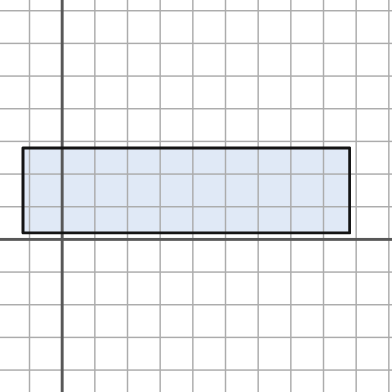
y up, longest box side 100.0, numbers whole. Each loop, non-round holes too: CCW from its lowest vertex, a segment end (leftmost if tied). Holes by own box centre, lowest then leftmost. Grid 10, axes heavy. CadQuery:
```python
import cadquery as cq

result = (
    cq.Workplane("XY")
    .moveTo(-12.0, 2.0)
    .lineTo(88.0, 2.0)
    .lineTo(88.0, 28.0)
    .lineTo(-12.0, 28.0)
    .close()
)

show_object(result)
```